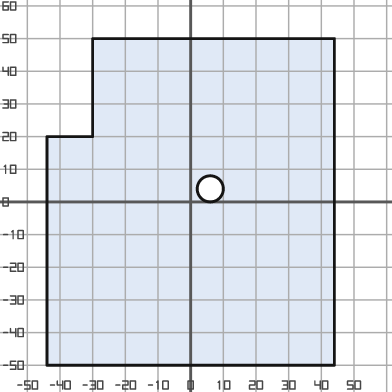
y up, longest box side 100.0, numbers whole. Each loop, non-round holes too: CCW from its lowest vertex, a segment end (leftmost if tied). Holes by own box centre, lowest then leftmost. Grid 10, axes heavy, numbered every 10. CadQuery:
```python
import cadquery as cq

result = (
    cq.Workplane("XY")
    .moveTo(-44.0, -50.0)
    .lineTo(44.0, -50.0)
    .lineTo(44.0, 50.0)
    .lineTo(-30.0, 50.0)
    .lineTo(-30.0, 20.0)
    .lineTo(-44.0, 20.0)
    .close()
    .moveTo(6.0, 4.0)
    .circle(4.0)
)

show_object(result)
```